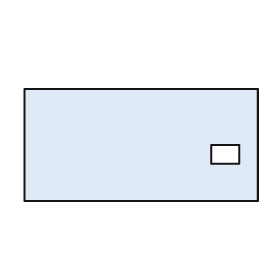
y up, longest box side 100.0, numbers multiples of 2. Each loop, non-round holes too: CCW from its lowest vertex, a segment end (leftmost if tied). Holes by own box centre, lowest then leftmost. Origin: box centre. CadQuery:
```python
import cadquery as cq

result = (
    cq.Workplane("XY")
    .moveTo(-50.0, -24.0)
    .lineTo(50.0, -24.0)
    .lineTo(50.0, 24.0)
    .lineTo(-50.0, 24.0)
    .close()
    .moveTo(30.0, -8.0)
    .lineTo(42.0, -8.0)
    .lineTo(42.0, 0.0)
    .lineTo(30.0, 0.0)
    .close()
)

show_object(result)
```